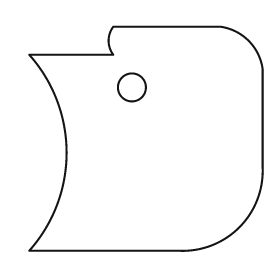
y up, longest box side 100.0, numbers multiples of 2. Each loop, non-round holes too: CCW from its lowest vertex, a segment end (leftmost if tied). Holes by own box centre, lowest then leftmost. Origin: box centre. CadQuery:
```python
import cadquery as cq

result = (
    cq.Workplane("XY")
    .moveTo(-50.0, -48.0)
    .lineTo(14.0, -48.0)
    .threePointArc((40.0, -38.0), (50.0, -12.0))
    .lineTo(50.0, 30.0)
    .threePointArc((44.0, 42.0), (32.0, 48.0))
    .lineTo(-14.0, 48.0)
    .threePointArc((-16.0, 42.0), (-14.0, 36.0))
    .lineTo(-50.0, 36.0)
    .threePointArc((-34.0, -6.0), (-50.0, -48.0))
    .close()
    .moveTo(-6.0, 22.0)
    .circle(6.0)
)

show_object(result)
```